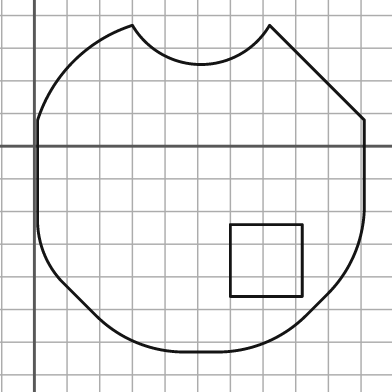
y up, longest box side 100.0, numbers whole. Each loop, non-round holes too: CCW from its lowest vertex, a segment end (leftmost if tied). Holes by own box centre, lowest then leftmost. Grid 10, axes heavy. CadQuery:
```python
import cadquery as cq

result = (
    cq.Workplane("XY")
    .moveTo(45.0, -63.0)
    .lineTo(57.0, -63.0)
    .threePointArc((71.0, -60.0), (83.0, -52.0))
    .lineTo(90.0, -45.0)
    .threePointArc((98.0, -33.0), (101.0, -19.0))
    .lineTo(101.0, 8.0)
    .lineTo(72.0, 37.0)
    .threePointArc((51.0, 25.0), (30.0, 37.0))
    .threePointArc((12.0, 26.0), (1.0, 8.0))
    .lineTo(1.0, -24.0)
    .threePointArc((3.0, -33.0), (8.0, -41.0))
    .lineTo(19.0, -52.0)
    .threePointArc((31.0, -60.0), (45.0, -63.0))
    .close()
    .moveTo(60.0, -46.0)
    .lineTo(82.0, -46.0)
    .lineTo(82.0, -24.0)
    .lineTo(60.0, -24.0)
    .close()
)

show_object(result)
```